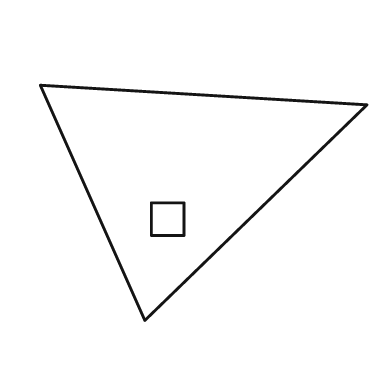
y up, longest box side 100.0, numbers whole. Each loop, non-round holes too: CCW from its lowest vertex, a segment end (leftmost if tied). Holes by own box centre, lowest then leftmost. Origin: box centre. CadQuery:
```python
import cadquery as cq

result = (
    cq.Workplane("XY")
    .moveTo(-18.0, -36.0)
    .lineTo(50.0, 30.0)
    .lineTo(-50.0, 36.0)
    .close()
    .moveTo(-16.0, -10.0)
    .lineTo(-6.0, -10.0)
    .lineTo(-6.0, 0.0)
    .lineTo(-16.0, 0.0)
    .close()
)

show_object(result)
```